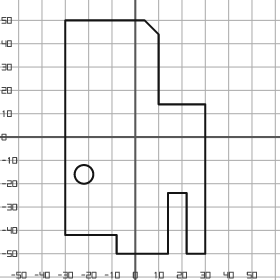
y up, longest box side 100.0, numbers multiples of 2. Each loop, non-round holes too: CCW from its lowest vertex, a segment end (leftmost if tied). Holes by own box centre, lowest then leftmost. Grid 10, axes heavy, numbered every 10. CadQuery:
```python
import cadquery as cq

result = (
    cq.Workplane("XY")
    .moveTo(-8.0, -50.0)
    .lineTo(14.0, -50.0)
    .lineTo(14.0, -24.0)
    .lineTo(22.0, -24.0)
    .lineTo(22.0, -50.0)
    .lineTo(30.0, -50.0)
    .lineTo(30.0, 14.0)
    .lineTo(10.0, 14.0)
    .lineTo(10.0, 44.0)
    .lineTo(4.0, 50.0)
    .lineTo(-30.0, 50.0)
    .lineTo(-30.0, -42.0)
    .lineTo(-8.0, -42.0)
    .close()
    .moveTo(-22.0, -16.0)
    .circle(4.0)
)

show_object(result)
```